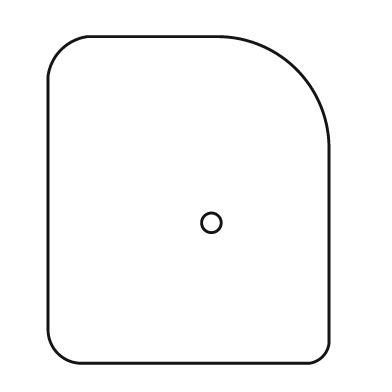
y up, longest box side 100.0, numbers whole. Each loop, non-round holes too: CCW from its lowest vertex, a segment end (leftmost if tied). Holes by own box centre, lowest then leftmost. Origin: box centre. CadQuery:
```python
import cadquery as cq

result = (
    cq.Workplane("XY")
    .moveTo(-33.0, -50.0)
    .lineTo(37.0, -50.0)
    .threePointArc((41.0, -48.0), (43.0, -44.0))
    .lineTo(43.0, 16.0)
    .threePointArc((33.0, 40.0), (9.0, 50.0))
    .lineTo(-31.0, 50.0)
    .threePointArc((-39.0, 46.0), (-43.0, 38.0))
    .lineTo(-43.0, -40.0)
    .threePointArc((-40.0, -47.0), (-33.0, -50.0))
    .close()
    .moveTo(7.0, -7.0)
    .circle(3.0)
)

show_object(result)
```